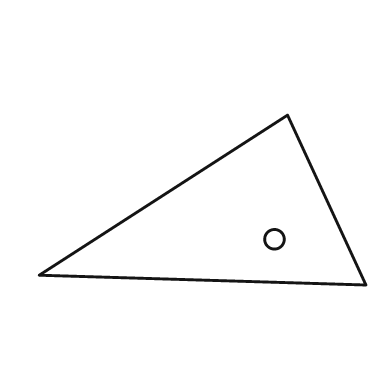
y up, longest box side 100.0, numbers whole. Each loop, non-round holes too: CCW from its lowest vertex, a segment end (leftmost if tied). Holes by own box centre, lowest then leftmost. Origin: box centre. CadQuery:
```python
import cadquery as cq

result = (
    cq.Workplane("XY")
    .moveTo(50.0, -26.0)
    .lineTo(26.0, 26.0)
    .lineTo(-50.0, -23.0)
    .close()
    .moveTo(22.0, -12.0)
    .circle(3.0)
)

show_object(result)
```